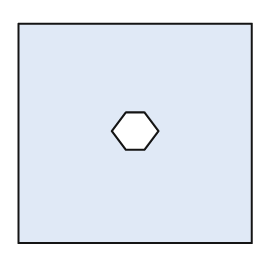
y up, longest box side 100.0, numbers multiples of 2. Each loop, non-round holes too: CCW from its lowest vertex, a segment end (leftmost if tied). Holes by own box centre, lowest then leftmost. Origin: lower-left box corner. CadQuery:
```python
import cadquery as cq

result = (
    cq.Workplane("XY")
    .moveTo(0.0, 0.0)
    .lineTo(100.0, 0.0)
    .lineTo(100.0, 94.0)
    .lineTo(0.0, 94.0)
    .close()
    .moveTo(46.0, 40.0)
    .lineTo(54.0, 40.0)
    .lineTo(60.0, 48.0)
    .lineTo(54.0, 56.0)
    .lineTo(46.0, 56.0)
    .lineTo(40.0, 48.0)
    .close()
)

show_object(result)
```